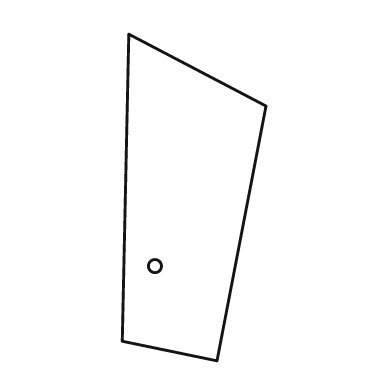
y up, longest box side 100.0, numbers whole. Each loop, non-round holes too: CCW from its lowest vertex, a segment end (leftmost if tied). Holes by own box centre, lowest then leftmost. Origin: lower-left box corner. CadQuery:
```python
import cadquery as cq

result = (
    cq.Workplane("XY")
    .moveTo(29.0, 0.0)
    .lineTo(44.0, 78.0)
    .lineTo(2.0, 100.0)
    .lineTo(0.0, 6.0)
    .close()
    .moveTo(10.0, 29.0)
    .circle(2.0)
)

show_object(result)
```